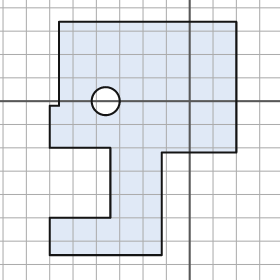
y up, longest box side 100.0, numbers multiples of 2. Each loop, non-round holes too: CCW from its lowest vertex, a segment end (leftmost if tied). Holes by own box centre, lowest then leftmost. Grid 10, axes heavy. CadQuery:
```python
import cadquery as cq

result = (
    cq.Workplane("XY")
    .moveTo(-60.0, -66.0)
    .lineTo(-12.0, -66.0)
    .lineTo(-12.0, -22.0)
    .lineTo(20.0, -22.0)
    .lineTo(20.0, 34.0)
    .lineTo(-56.0, 34.0)
    .lineTo(-56.0, -2.0)
    .lineTo(-60.0, -2.0)
    .lineTo(-60.0, -20.0)
    .lineTo(-34.0, -20.0)
    .lineTo(-34.0, -50.0)
    .lineTo(-60.0, -50.0)
    .close()
    .moveTo(-36.0, 0.0)
    .circle(6.0)
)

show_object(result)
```